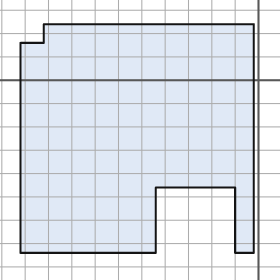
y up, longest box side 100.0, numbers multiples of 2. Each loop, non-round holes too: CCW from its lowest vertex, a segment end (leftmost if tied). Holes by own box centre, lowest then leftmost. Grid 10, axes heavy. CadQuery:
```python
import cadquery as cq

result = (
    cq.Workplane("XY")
    .moveTo(-102.0, -74.0)
    .lineTo(-44.0, -74.0)
    .lineTo(-44.0, -46.0)
    .lineTo(-10.0, -46.0)
    .lineTo(-10.0, -74.0)
    .lineTo(-2.0, -74.0)
    .lineTo(-2.0, 24.0)
    .lineTo(-92.0, 24.0)
    .lineTo(-92.0, 16.0)
    .lineTo(-102.0, 16.0)
    .close()
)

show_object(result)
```